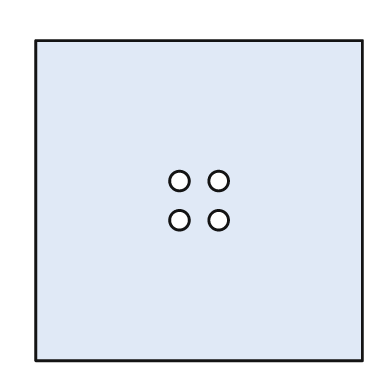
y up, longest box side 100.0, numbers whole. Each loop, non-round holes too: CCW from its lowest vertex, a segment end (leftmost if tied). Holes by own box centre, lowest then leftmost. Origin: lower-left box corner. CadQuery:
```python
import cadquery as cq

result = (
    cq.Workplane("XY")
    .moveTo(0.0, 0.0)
    .lineTo(100.0, 0.0)
    .lineTo(100.0, 98.0)
    .lineTo(0.0, 98.0)
    .close()
    .moveTo(44.0, 43.0)
    .circle(3.0)
    .moveTo(56.0, 43.0)
    .circle(3.0)
    .moveTo(44.0, 55.0)
    .circle(3.0)
    .moveTo(56.0, 55.0)
    .circle(3.0)
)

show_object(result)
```